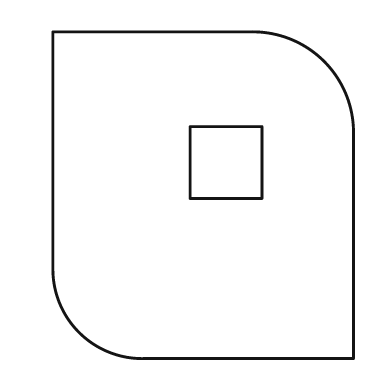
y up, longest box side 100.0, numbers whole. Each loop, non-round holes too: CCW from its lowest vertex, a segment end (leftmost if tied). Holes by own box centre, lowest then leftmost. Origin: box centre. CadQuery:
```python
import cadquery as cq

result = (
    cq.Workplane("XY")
    .moveTo(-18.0, -50.0)
    .lineTo(46.0, -50.0)
    .lineTo(46.0, 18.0)
    .threePointArc((37.0, 41.0), (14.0, 50.0))
    .lineTo(-46.0, 50.0)
    .lineTo(-46.0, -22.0)
    .threePointArc((-38.0, -42.0), (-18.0, -50.0))
    .close()
    .moveTo(-4.0, -1.0)
    .lineTo(18.0, -1.0)
    .lineTo(18.0, 21.0)
    .lineTo(-4.0, 21.0)
    .close()
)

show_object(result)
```